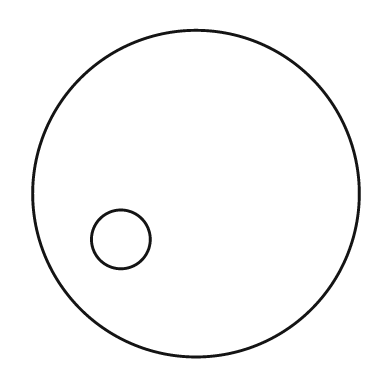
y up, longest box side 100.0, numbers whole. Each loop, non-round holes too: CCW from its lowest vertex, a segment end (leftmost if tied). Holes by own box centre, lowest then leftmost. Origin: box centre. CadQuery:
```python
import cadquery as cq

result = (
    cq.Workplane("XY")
    .moveTo(0.0, 0.0)
    .circle(50.0)
    .moveTo(-23.0, -14.0)
    .circle(9.0)
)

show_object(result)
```